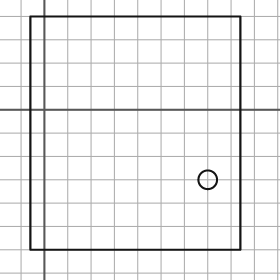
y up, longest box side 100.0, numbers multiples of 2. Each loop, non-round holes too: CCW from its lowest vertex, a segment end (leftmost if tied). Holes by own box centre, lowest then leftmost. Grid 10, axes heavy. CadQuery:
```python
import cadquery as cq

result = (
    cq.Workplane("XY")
    .moveTo(-6.0, -60.0)
    .lineTo(84.0, -60.0)
    .lineTo(84.0, 40.0)
    .lineTo(-6.0, 40.0)
    .close()
    .moveTo(70.0, -30.0)
    .circle(4.0)
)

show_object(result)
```